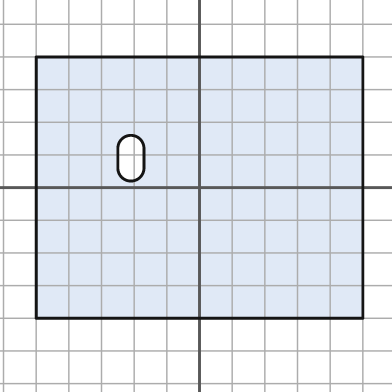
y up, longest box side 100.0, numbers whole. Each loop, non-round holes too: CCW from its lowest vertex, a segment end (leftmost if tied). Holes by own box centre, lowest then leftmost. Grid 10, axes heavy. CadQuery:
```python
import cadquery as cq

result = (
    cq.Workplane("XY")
    .moveTo(-50.0, -40.0)
    .lineTo(50.0, -40.0)
    .lineTo(50.0, 40.0)
    .lineTo(-50.0, 40.0)
    .close()
    .moveTo(-25.0, 6.0)
    .threePointArc((-21.0, 2.0), (-17.0, 6.0))
    .lineTo(-17.0, 12.0)
    .threePointArc((-21.0, 16.0), (-25.0, 12.0))
    .close()
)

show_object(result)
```